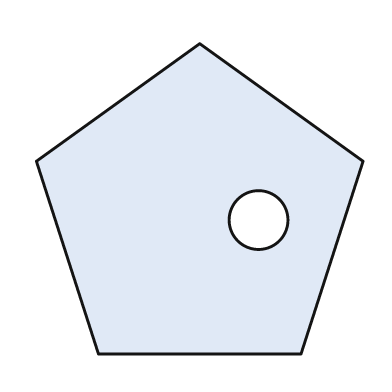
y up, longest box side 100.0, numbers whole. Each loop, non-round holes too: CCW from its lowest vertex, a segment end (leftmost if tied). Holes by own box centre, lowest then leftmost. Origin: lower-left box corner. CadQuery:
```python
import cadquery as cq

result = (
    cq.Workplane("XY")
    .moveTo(19.0, 0.0)
    .lineTo(81.0, 0.0)
    .lineTo(100.0, 59.0)
    .lineTo(50.0, 95.0)
    .lineTo(0.0, 59.0)
    .close()
    .moveTo(68.0, 41.0)
    .circle(9.0)
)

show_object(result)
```